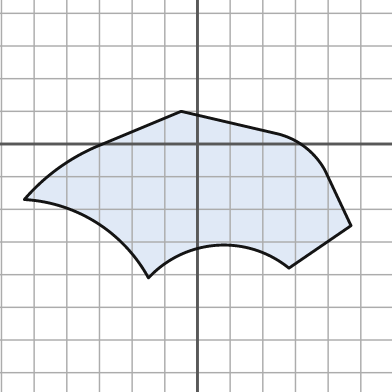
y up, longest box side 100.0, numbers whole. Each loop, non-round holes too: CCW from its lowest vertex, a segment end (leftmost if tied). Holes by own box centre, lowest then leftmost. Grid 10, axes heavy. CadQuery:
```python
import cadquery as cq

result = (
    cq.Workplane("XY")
    .moveTo(-15.0, -41.0)
    .threePointArc((6.0, -31.0), (28.0, -38.0))
    .lineTo(47.0, -25.0)
    .lineTo(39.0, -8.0)
    .threePointArc((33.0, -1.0), (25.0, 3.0))
    .lineTo(-5.0, 10.0)
    .lineTo(-29.0, 0.0)
    .threePointArc((-42.0, -7.0), (-53.0, -17.0))
    .threePointArc((-31.0, -24.0), (-15.0, -41.0))
    .close()
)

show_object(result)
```